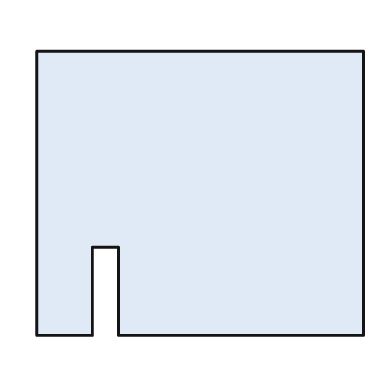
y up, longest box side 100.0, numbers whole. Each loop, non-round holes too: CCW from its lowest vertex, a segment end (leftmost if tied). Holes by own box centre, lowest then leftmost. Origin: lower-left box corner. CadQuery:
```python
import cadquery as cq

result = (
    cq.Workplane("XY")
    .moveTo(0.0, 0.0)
    .lineTo(17.0, 0.0)
    .lineTo(17.0, 27.0)
    .lineTo(25.0, 27.0)
    .lineTo(25.0, 0.0)
    .lineTo(100.0, 0.0)
    .lineTo(100.0, 87.0)
    .lineTo(0.0, 87.0)
    .close()
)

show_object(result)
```